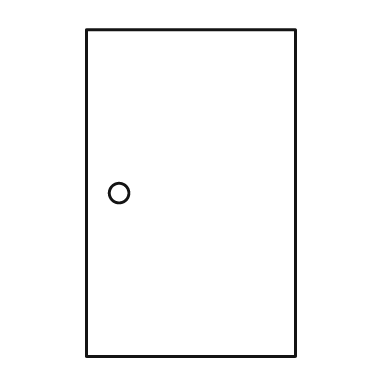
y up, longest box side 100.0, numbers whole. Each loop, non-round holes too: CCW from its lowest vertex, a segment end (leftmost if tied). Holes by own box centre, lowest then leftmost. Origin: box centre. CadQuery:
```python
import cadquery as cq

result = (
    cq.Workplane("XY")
    .moveTo(-32.0, -50.0)
    .lineTo(32.0, -50.0)
    .lineTo(32.0, 50.0)
    .lineTo(-32.0, 50.0)
    .close()
    .moveTo(-22.0, 0.0)
    .circle(3.0)
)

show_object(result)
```